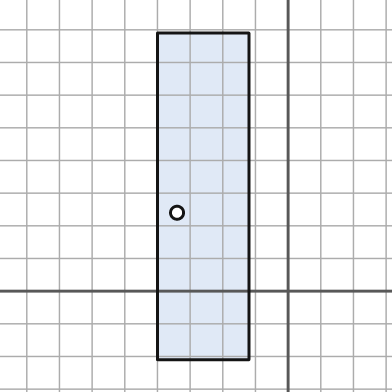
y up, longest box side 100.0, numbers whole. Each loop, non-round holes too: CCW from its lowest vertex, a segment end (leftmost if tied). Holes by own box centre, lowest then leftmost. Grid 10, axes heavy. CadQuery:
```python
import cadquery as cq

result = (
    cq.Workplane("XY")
    .moveTo(-40.0, -21.0)
    .lineTo(-12.0, -21.0)
    .lineTo(-12.0, 79.0)
    .lineTo(-40.0, 79.0)
    .close()
    .moveTo(-34.0, 24.0)
    .circle(2.0)
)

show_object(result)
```